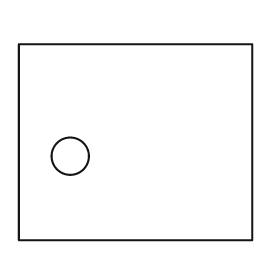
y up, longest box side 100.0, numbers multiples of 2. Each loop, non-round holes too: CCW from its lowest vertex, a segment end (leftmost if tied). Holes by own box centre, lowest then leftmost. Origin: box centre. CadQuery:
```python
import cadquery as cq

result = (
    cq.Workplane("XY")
    .moveTo(-50.0, -42.0)
    .lineTo(50.0, -42.0)
    .lineTo(50.0, 42.0)
    .lineTo(-50.0, 42.0)
    .close()
    .moveTo(-28.0, -6.0)
    .circle(8.0)
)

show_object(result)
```